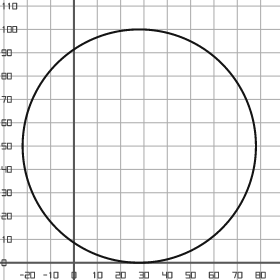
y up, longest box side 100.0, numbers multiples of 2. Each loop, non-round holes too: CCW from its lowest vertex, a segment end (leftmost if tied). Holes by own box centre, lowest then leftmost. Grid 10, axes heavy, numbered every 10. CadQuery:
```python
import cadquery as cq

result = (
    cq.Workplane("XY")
    .moveTo(28.0, 50.0)
    .circle(50.0)
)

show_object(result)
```